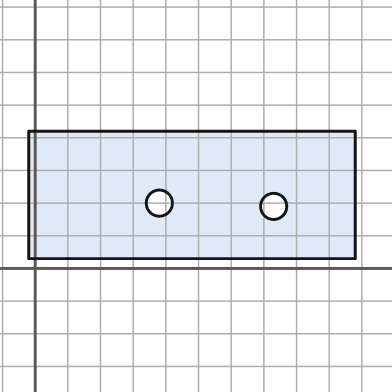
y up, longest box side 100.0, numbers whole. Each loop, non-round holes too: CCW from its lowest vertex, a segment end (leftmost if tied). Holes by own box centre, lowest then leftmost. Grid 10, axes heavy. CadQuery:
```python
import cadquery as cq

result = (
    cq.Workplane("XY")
    .moveTo(-2.0, 3.0)
    .lineTo(98.0, 3.0)
    .lineTo(98.0, 42.0)
    .lineTo(-2.0, 42.0)
    .close()
    .moveTo(73.0, 19.0)
    .circle(4.0)
    .moveTo(38.0, 20.0)
    .circle(4.0)
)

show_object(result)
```